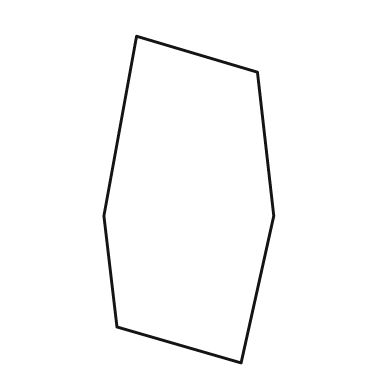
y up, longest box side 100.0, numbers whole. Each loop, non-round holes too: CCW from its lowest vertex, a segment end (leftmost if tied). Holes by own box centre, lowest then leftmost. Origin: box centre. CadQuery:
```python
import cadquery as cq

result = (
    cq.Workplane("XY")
    .moveTo(16.0, -50.0)
    .lineTo(26.0, -5.0)
    .lineTo(21.0, 39.0)
    .lineTo(-16.0, 50.0)
    .lineTo(-26.0, -5.0)
    .lineTo(-22.0, -39.0)
    .close()
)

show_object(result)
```